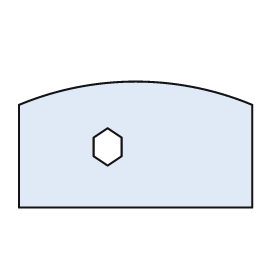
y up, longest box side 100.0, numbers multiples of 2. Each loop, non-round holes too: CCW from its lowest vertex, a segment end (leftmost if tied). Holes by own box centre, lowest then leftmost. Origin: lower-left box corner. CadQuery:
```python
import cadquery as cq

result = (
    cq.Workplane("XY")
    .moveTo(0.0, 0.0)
    .lineTo(100.0, 0.0)
    .lineTo(100.0, 44.0)
    .threePointArc((50.0, 54.0), (0.0, 44.0))
    .close()
    .moveTo(38.0, 18.0)
    .lineTo(44.0, 22.0)
    .lineTo(44.0, 30.0)
    .lineTo(38.0, 34.0)
    .lineTo(32.0, 30.0)
    .lineTo(32.0, 22.0)
    .close()
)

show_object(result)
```